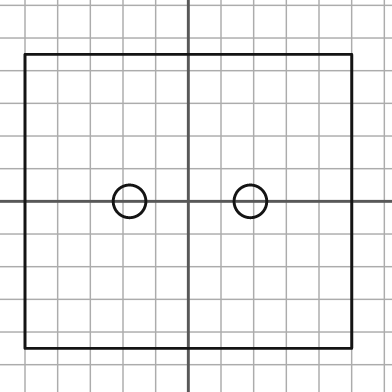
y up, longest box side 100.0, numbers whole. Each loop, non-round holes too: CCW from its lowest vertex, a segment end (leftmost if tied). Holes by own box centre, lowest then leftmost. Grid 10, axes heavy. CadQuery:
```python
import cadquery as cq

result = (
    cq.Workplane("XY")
    .moveTo(-50.0, -45.0)
    .lineTo(50.0, -45.0)
    .lineTo(50.0, 45.0)
    .lineTo(-50.0, 45.0)
    .close()
    .moveTo(-18.0, 0.0)
    .circle(5.0)
    .moveTo(19.0, 0.0)
    .circle(5.0)
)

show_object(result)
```